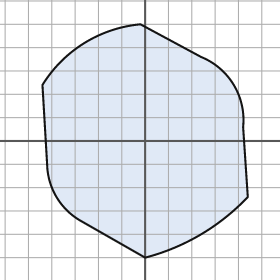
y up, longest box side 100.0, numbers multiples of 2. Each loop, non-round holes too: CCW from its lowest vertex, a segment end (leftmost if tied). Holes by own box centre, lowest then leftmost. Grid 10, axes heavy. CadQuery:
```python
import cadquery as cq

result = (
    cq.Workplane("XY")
    .moveTo(0.0, -50.0)
    .threePointArc((24.0, -40.0), (44.0, -24.0))
    .lineTo(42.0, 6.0)
    .threePointArc((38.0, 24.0), (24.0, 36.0))
    .lineTo(-2.0, 50.0)
    .threePointArc((-26.0, 42.0), (-44.0, 24.0))
    .lineTo(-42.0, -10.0)
    .threePointArc((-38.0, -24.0), (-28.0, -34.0))
    .close()
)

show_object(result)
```